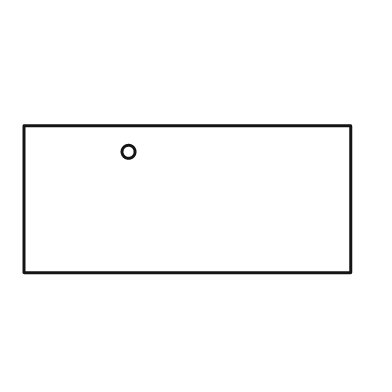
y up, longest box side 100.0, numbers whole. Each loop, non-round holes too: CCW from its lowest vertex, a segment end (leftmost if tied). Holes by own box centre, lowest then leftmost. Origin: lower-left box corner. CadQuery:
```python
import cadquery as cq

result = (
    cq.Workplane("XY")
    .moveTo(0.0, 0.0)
    .lineTo(100.0, 0.0)
    .lineTo(100.0, 45.0)
    .lineTo(0.0, 45.0)
    .close()
    .moveTo(32.0, 37.0)
    .circle(2.0)
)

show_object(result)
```